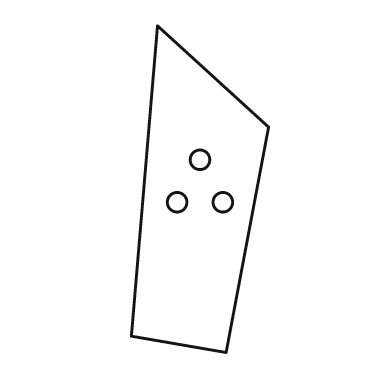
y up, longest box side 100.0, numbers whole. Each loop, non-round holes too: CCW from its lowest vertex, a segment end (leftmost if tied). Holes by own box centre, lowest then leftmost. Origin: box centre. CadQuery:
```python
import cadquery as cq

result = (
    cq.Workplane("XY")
    .moveTo(8.0, -50.0)
    .lineTo(21.0, 19.0)
    .lineTo(-13.0, 50.0)
    .lineTo(-21.0, -45.0)
    .close()
    .moveTo(-7.0, -4.0)
    .circle(3.0)
    .moveTo(7.0, -4.0)
    .circle(3.0)
    .moveTo(0.0, 9.0)
    .circle(3.0)
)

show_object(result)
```